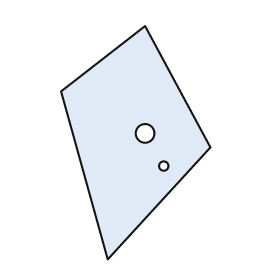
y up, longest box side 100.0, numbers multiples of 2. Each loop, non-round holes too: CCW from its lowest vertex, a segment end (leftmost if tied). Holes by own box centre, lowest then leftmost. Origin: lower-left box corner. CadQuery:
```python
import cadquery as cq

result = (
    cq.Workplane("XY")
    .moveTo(20.0, 0.0)
    .lineTo(64.0, 48.0)
    .lineTo(36.0, 100.0)
    .lineTo(0.0, 72.0)
    .close()
    .moveTo(44.0, 40.0)
    .circle(2.0)
    .moveTo(36.0, 54.0)
    .circle(4.0)
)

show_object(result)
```